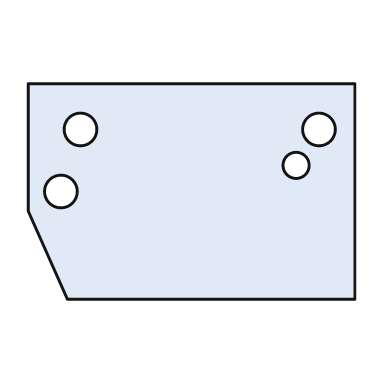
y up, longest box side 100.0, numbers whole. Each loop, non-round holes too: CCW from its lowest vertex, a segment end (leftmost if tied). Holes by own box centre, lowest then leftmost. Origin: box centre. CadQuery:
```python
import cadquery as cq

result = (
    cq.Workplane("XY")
    .moveTo(-38.0, -33.0)
    .lineTo(50.0, -33.0)
    .lineTo(50.0, 33.0)
    .lineTo(-50.0, 33.0)
    .lineTo(-50.0, -6.0)
    .close()
    .moveTo(-40.0, 0.0)
    .circle(5.0)
    .moveTo(32.0, 8.0)
    .circle(4.0)
    .moveTo(-34.0, 19.0)
    .circle(5.0)
    .moveTo(39.0, 19.0)
    .circle(5.0)
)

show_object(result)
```